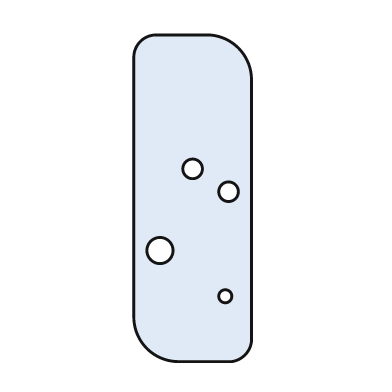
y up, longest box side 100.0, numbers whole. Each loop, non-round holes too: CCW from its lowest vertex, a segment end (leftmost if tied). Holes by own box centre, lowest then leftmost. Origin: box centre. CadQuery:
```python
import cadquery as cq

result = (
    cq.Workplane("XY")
    .moveTo(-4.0, -50.0)
    .lineTo(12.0, -50.0)
    .threePointArc((16.0, -48.0), (18.0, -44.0))
    .lineTo(18.0, 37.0)
    .threePointArc((14.0, 46.0), (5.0, 50.0))
    .lineTo(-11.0, 50.0)
    .threePointArc((-16.0, 48.0), (-18.0, 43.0))
    .lineTo(-18.0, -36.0)
    .threePointArc((-14.0, -46.0), (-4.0, -50.0))
    .close()
    .moveTo(10.0, -30.0)
    .circle(2.0)
    .moveTo(-10.0, -16.0)
    .circle(4.0)
    .moveTo(11.0, 2.0)
    .circle(3.0)
    .moveTo(0.0, 9.0)
    .circle(3.0)
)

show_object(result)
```